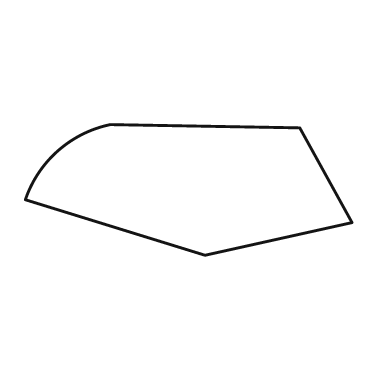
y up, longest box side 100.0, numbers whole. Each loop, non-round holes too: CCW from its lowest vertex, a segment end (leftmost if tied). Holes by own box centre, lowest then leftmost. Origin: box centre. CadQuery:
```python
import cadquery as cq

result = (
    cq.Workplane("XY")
    .moveTo(5.0, -20.0)
    .lineTo(50.0, -10.0)
    .lineTo(34.0, 19.0)
    .lineTo(-24.0, 20.0)
    .threePointArc((-40.0, 12.0), (-50.0, -3.0))
    .close()
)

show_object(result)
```